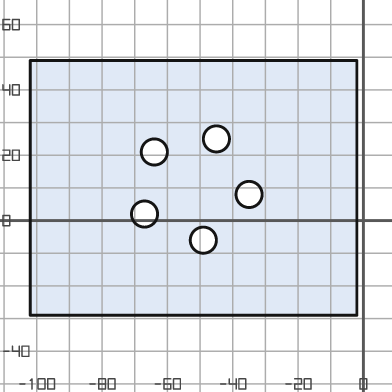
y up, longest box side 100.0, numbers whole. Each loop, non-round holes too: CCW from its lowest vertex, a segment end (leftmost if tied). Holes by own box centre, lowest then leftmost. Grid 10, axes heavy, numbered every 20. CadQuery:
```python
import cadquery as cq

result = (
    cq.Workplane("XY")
    .moveTo(-102.0, -29.0)
    .lineTo(-2.0, -29.0)
    .lineTo(-2.0, 49.0)
    .lineTo(-102.0, 49.0)
    .close()
    .moveTo(-49.0, -6.0)
    .circle(4.0)
    .moveTo(-67.0, 2.0)
    .circle(4.0)
    .moveTo(-35.0, 8.0)
    .circle(4.0)
    .moveTo(-64.0, 21.0)
    .circle(4.0)
    .moveTo(-45.0, 25.0)
    .circle(4.0)
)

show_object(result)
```